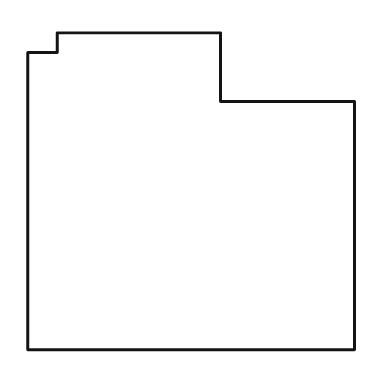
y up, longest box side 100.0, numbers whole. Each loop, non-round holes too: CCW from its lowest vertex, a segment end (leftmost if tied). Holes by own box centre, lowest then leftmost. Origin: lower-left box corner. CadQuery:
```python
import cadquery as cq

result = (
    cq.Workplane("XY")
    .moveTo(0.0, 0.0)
    .lineTo(100.0, 0.0)
    .lineTo(100.0, 76.0)
    .lineTo(59.0, 76.0)
    .lineTo(59.0, 97.0)
    .lineTo(9.0, 97.0)
    .lineTo(9.0, 91.0)
    .lineTo(0.0, 91.0)
    .close()
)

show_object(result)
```